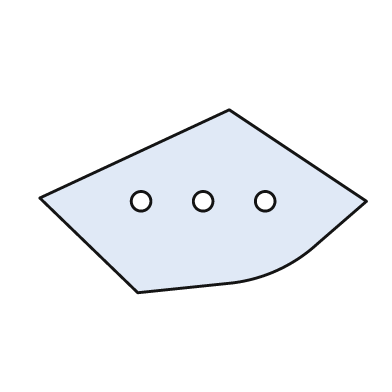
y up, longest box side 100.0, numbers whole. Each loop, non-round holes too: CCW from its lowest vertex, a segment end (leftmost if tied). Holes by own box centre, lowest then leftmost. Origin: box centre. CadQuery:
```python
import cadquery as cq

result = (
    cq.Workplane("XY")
    .moveTo(-20.0, -28.0)
    .lineTo(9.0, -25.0)
    .threePointArc((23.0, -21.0), (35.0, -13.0))
    .lineTo(50.0, 0.0)
    .lineTo(8.0, 28.0)
    .lineTo(-50.0, 1.0)
    .close()
    .moveTo(-19.0, 0.0)
    .circle(3.0)
    .moveTo(0.0, 0.0)
    .circle(3.0)
    .moveTo(19.0, 0.0)
    .circle(3.0)
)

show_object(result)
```